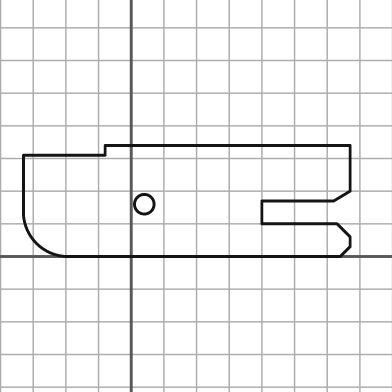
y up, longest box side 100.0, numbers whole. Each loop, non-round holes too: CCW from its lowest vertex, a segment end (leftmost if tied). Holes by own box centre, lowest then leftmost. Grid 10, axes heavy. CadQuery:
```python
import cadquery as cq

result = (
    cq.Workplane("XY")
    .moveTo(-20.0, 0.0)
    .lineTo(64.0, 0.0)
    .lineTo(67.0, 3.0)
    .lineTo(67.0, 6.0)
    .lineTo(63.0, 10.0)
    .lineTo(40.0, 10.0)
    .lineTo(40.0, 17.0)
    .lineTo(62.0, 17.0)
    .lineTo(67.0, 20.0)
    .lineTo(67.0, 34.0)
    .lineTo(-8.0, 34.0)
    .lineTo(-8.0, 31.0)
    .lineTo(-33.0, 31.0)
    .lineTo(-33.0, 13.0)
    .threePointArc((-29.0, 4.0), (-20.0, 0.0))
    .close()
    .moveTo(4.0, 16.0)
    .circle(3.0)
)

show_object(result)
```